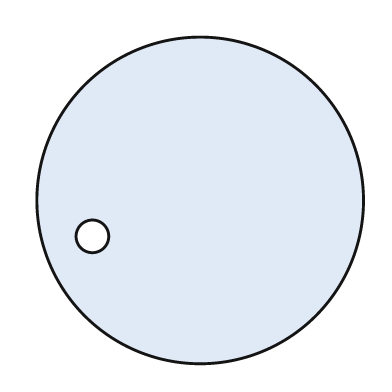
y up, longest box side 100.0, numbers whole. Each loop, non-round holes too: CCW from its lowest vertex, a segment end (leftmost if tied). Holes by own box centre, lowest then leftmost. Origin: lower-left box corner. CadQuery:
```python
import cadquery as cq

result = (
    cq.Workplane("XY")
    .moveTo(50.0, 50.0)
    .circle(50.0)
    .moveTo(17.0, 39.0)
    .circle(5.0)
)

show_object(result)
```